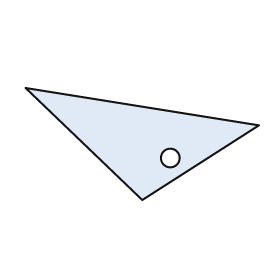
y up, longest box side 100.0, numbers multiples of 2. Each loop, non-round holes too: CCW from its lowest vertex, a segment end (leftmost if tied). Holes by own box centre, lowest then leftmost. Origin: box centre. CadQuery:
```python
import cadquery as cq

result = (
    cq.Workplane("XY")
    .moveTo(0.0, -24.0)
    .lineTo(50.0, 8.0)
    .lineTo(-50.0, 24.0)
    .close()
    .moveTo(12.0, -6.0)
    .circle(4.0)
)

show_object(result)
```